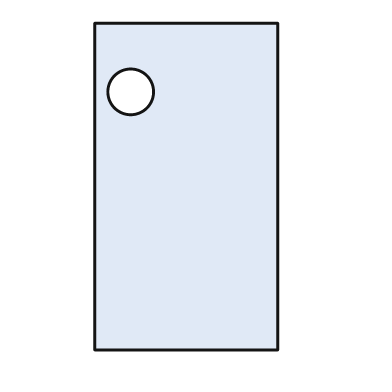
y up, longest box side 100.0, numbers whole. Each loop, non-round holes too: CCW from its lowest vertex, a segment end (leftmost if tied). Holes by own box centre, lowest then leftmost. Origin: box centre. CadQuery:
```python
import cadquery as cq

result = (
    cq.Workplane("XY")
    .moveTo(-28.0, -50.0)
    .lineTo(28.0, -50.0)
    .lineTo(28.0, 50.0)
    .lineTo(-28.0, 50.0)
    .close()
    .moveTo(-17.0, 29.0)
    .circle(7.0)
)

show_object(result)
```